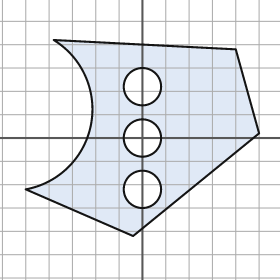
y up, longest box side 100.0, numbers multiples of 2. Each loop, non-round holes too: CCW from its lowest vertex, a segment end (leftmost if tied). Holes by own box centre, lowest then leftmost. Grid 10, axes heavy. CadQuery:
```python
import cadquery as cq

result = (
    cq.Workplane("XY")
    .moveTo(-4.0, -42.0)
    .lineTo(50.0, 2.0)
    .lineTo(40.0, 38.0)
    .lineTo(-38.0, 42.0)
    .threePointArc((-22.0, 6.0), (-50.0, -22.0))
    .close()
    .moveTo(0.0, -22.0)
    .circle(8.0)
    .moveTo(0.0, 0.0)
    .circle(8.0)
    .moveTo(0.0, 22.0)
    .circle(8.0)
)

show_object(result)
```